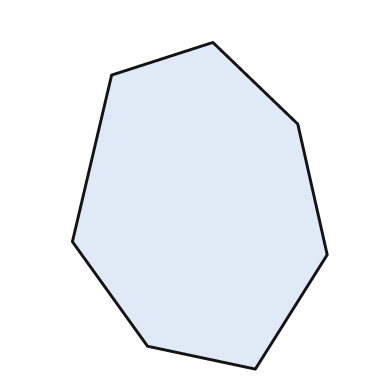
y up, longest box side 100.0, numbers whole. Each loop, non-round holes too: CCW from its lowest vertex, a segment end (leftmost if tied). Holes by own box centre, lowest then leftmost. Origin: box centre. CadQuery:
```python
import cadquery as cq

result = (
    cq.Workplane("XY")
    .moveTo(17.0, -50.0)
    .lineTo(39.0, -15.0)
    .lineTo(30.0, 25.0)
    .lineTo(4.0, 50.0)
    .lineTo(-27.0, 40.0)
    .lineTo(-39.0, -11.0)
    .lineTo(-16.0, -43.0)
    .close()
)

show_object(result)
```